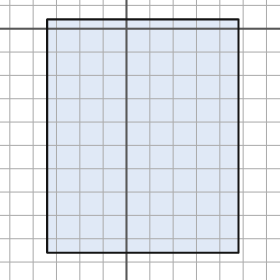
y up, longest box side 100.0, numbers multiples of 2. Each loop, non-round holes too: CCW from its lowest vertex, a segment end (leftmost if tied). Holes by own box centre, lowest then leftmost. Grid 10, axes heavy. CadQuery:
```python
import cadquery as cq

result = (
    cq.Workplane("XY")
    .moveTo(-34.0, -96.0)
    .lineTo(48.0, -96.0)
    .lineTo(48.0, 4.0)
    .lineTo(-34.0, 4.0)
    .close()
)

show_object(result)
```